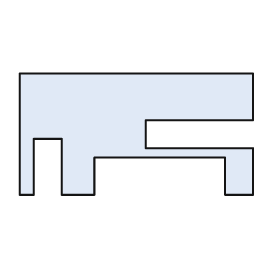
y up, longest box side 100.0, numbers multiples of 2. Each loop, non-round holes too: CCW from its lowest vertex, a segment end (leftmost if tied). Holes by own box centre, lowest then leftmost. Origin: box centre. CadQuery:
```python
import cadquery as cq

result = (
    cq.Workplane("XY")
    .moveTo(-50.0, -26.0)
    .lineTo(-44.0, -26.0)
    .lineTo(-44.0, -2.0)
    .lineTo(-32.0, -2.0)
    .lineTo(-32.0, -26.0)
    .lineTo(-18.0, -26.0)
    .lineTo(-18.0, -10.0)
    .lineTo(38.0, -10.0)
    .lineTo(38.0, -26.0)
    .lineTo(50.0, -26.0)
    .lineTo(50.0, -6.0)
    .lineTo(4.0, -6.0)
    .lineTo(4.0, 6.0)
    .lineTo(50.0, 6.0)
    .lineTo(50.0, 26.0)
    .lineTo(-50.0, 26.0)
    .close()
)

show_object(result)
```